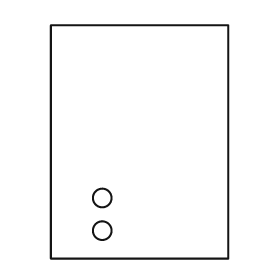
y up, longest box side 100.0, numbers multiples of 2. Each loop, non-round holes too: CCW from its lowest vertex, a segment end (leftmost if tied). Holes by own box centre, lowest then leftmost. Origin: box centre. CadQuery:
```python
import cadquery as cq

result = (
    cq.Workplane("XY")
    .moveTo(-38.0, -50.0)
    .lineTo(38.0, -50.0)
    .lineTo(38.0, 50.0)
    .lineTo(-38.0, 50.0)
    .close()
    .moveTo(-16.0, -38.0)
    .circle(4.0)
    .moveTo(-16.0, -24.0)
    .circle(4.0)
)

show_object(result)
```